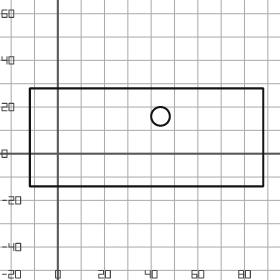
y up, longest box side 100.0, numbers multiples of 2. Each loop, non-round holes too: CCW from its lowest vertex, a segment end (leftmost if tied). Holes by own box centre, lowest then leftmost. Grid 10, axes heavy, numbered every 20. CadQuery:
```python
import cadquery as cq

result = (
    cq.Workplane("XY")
    .moveTo(-12.0, -14.0)
    .lineTo(88.0, -14.0)
    .lineTo(88.0, 28.0)
    .lineTo(-12.0, 28.0)
    .close()
    .moveTo(44.0, 16.0)
    .circle(4.0)
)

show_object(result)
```